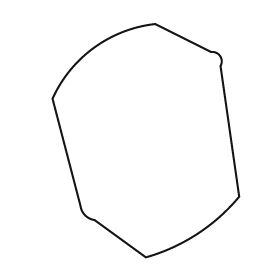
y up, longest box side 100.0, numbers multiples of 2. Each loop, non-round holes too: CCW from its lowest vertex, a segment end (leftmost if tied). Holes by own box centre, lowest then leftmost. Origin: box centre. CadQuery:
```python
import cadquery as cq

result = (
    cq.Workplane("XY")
    .moveTo(0.0, -50.0)
    .threePointArc((22.0, -40.0), (40.0, -24.0))
    .lineTo(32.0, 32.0)
    .threePointArc((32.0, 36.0), (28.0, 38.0))
    .lineTo(4.0, 50.0)
    .threePointArc((-22.0, 40.0), (-40.0, 18.0))
    .lineTo(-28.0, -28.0)
    .threePointArc((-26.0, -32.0), (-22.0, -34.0))
    .close()
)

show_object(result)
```